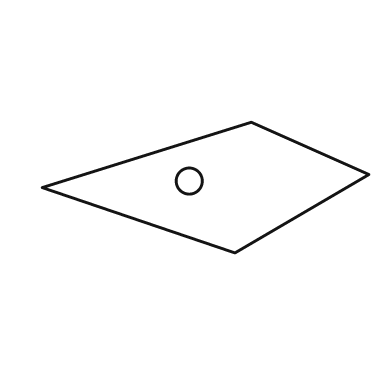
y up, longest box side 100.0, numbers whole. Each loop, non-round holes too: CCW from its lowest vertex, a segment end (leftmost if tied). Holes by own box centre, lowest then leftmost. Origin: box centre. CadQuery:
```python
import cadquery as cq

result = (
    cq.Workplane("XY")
    .moveTo(9.0, -20.0)
    .lineTo(50.0, 4.0)
    .lineTo(14.0, 20.0)
    .lineTo(-50.0, 0.0)
    .close()
    .moveTo(-5.0, 2.0)
    .circle(4.0)
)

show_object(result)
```